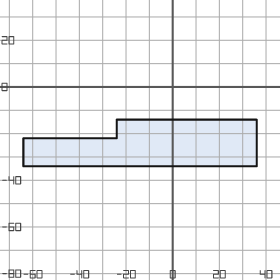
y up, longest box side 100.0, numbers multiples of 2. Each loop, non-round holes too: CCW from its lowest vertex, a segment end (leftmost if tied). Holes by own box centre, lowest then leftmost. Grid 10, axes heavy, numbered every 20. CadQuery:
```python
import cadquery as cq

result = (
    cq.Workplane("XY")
    .moveTo(-64.0, -34.0)
    .lineTo(36.0, -34.0)
    .lineTo(36.0, -14.0)
    .lineTo(-24.0, -14.0)
    .lineTo(-24.0, -22.0)
    .lineTo(-64.0, -22.0)
    .close()
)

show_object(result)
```